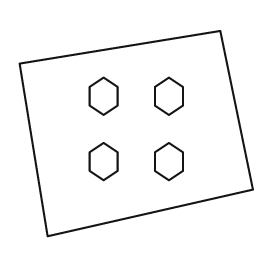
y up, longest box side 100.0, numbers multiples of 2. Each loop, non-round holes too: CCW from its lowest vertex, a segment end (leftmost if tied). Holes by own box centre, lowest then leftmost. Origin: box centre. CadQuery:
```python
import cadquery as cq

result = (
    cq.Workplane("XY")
    .moveTo(-38.0, -44.0)
    .lineTo(50.0, -24.0)
    .lineTo(36.0, 44.0)
    .lineTo(-50.0, 30.0)
    .close()
    .moveTo(-14.0, -20.0)
    .lineTo(-8.0, -16.0)
    .lineTo(-8.0, -8.0)
    .lineTo(-14.0, -4.0)
    .lineTo(-20.0, -8.0)
    .lineTo(-20.0, -16.0)
    .close()
    .moveTo(14.0, -20.0)
    .lineTo(20.0, -16.0)
    .lineTo(20.0, -8.0)
    .lineTo(14.0, -4.0)
    .lineTo(8.0, -8.0)
    .lineTo(8.0, -16.0)
    .close()
    .moveTo(-14.0, 8.0)
    .lineTo(-8.0, 12.0)
    .lineTo(-8.0, 20.0)
    .lineTo(-14.0, 24.0)
    .lineTo(-20.0, 20.0)
    .lineTo(-20.0, 12.0)
    .close()
    .moveTo(14.0, 8.0)
    .lineTo(20.0, 12.0)
    .lineTo(20.0, 20.0)
    .lineTo(14.0, 24.0)
    .lineTo(8.0, 20.0)
    .lineTo(8.0, 12.0)
    .close()
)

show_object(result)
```